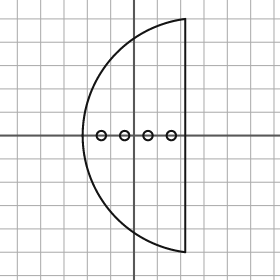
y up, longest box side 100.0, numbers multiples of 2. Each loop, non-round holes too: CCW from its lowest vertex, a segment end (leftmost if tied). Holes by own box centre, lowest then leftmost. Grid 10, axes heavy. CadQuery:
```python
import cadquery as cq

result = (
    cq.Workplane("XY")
    .moveTo(22.0, -50.0)
    .lineTo(22.0, 50.0)
    .threePointArc((-22.0, 0.0), (22.0, -50.0))
    .close()
    .moveTo(-14.0, 0.0)
    .circle(2.0)
    .moveTo(-4.0, 0.0)
    .circle(2.0)
    .moveTo(6.0, 0.0)
    .circle(2.0)
    .moveTo(16.0, 0.0)
    .circle(2.0)
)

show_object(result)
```